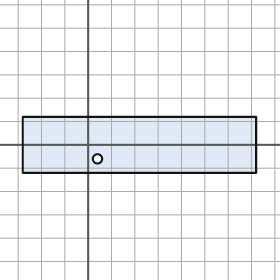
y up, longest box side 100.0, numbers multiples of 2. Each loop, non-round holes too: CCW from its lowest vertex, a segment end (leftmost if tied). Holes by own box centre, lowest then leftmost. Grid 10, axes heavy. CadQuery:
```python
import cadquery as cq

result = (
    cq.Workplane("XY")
    .moveTo(-28.0, -12.0)
    .lineTo(72.0, -12.0)
    .lineTo(72.0, 12.0)
    .lineTo(-28.0, 12.0)
    .close()
    .moveTo(4.0, -6.0)
    .circle(2.0)
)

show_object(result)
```